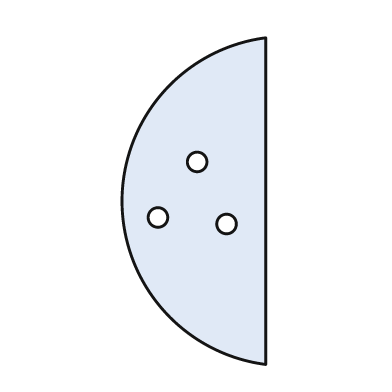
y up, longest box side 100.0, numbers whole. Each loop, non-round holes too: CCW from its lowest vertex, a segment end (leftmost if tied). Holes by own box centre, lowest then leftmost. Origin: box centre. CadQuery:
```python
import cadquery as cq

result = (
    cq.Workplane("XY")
    .moveTo(22.0, -50.0)
    .lineTo(22.0, 50.0)
    .threePointArc((-22.0, 0.0), (22.0, -50.0))
    .close()
    .moveTo(10.0, -7.0)
    .circle(3.0)
    .moveTo(-11.0, -5.0)
    .circle(3.0)
    .moveTo(1.0, 12.0)
    .circle(3.0)
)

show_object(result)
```